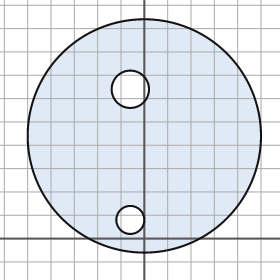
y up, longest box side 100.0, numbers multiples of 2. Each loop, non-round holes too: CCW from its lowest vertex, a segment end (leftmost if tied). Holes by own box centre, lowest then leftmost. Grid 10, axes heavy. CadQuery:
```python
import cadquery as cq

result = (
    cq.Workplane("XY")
    .moveTo(0.0, 44.0)
    .circle(50.0)
    .moveTo(-6.0, 8.0)
    .circle(6.0)
    .moveTo(-6.0, 64.0)
    .circle(8.0)
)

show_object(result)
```